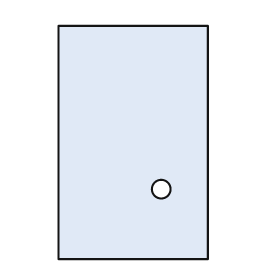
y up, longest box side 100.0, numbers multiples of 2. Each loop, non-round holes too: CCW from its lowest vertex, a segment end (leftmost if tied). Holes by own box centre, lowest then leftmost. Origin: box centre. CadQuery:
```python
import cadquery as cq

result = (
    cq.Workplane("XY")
    .moveTo(-32.0, -50.0)
    .lineTo(32.0, -50.0)
    .lineTo(32.0, 50.0)
    .lineTo(-32.0, 50.0)
    .close()
    .moveTo(12.0, -20.0)
    .circle(4.0)
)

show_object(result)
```